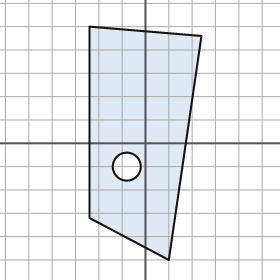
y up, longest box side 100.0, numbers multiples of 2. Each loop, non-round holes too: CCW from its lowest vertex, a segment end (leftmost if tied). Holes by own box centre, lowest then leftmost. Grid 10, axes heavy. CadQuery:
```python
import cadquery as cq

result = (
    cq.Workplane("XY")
    .moveTo(10.0, -50.0)
    .lineTo(24.0, 46.0)
    .lineTo(-24.0, 50.0)
    .lineTo(-24.0, -32.0)
    .close()
    .moveTo(-8.0, -10.0)
    .circle(6.0)
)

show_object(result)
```